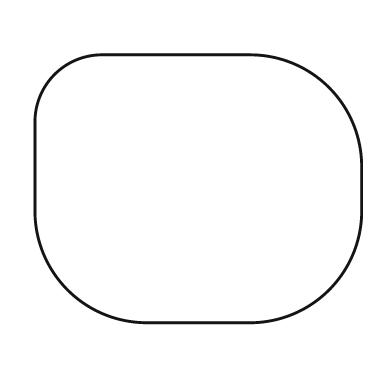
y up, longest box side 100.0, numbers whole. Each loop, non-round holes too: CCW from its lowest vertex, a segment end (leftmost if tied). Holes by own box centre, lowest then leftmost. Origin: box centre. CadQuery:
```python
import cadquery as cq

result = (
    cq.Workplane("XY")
    .moveTo(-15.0, -41.0)
    .lineTo(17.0, -41.0)
    .threePointArc((40.0, -31.0), (50.0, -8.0))
    .lineTo(50.0, 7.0)
    .threePointArc((40.0, 31.0), (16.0, 41.0))
    .lineTo(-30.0, 41.0)
    .threePointArc((-44.0, 35.0), (-50.0, 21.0))
    .lineTo(-50.0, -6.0)
    .threePointArc((-40.0, -31.0), (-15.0, -41.0))
    .close()
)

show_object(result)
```